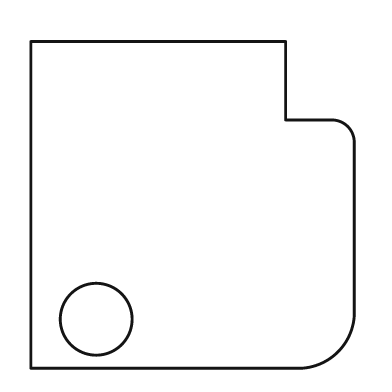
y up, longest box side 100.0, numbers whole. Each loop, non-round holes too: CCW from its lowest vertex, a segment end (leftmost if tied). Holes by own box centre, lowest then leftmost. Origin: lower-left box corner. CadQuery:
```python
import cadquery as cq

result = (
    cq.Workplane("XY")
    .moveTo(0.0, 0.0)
    .lineTo(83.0, 0.0)
    .threePointArc((94.0, 5.0), (99.0, 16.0))
    .lineTo(99.0, 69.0)
    .threePointArc((97.0, 74.0), (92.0, 76.0))
    .lineTo(78.0, 76.0)
    .lineTo(78.0, 100.0)
    .lineTo(0.0, 100.0)
    .close()
    .moveTo(20.0, 15.0)
    .circle(11.0)
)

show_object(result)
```